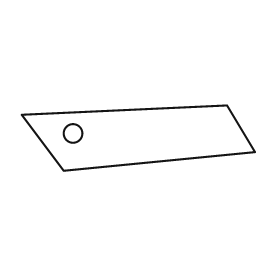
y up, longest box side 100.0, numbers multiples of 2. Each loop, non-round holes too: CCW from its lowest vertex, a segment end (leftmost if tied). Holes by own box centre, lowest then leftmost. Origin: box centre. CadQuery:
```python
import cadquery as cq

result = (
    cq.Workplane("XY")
    .moveTo(-32.0, -14.0)
    .lineTo(50.0, -6.0)
    .lineTo(38.0, 14.0)
    .lineTo(-50.0, 10.0)
    .close()
    .moveTo(-28.0, 2.0)
    .circle(4.0)
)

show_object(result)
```